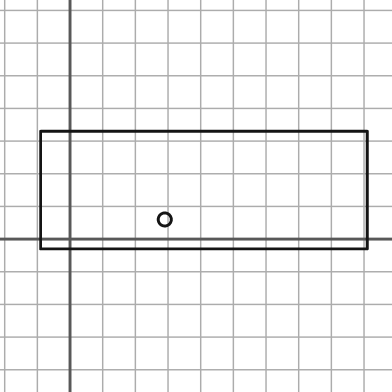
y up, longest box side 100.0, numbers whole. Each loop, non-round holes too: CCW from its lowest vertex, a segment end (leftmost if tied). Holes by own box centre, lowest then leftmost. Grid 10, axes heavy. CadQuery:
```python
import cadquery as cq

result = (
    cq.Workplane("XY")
    .moveTo(-9.0, -3.0)
    .lineTo(91.0, -3.0)
    .lineTo(91.0, 33.0)
    .lineTo(-9.0, 33.0)
    .close()
    .moveTo(29.0, 6.0)
    .circle(2.0)
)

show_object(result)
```